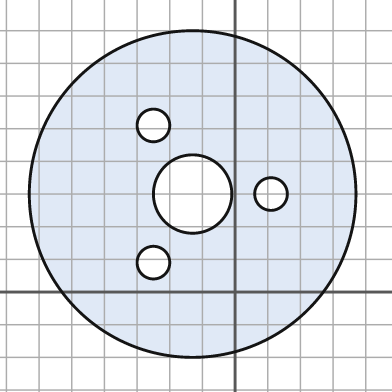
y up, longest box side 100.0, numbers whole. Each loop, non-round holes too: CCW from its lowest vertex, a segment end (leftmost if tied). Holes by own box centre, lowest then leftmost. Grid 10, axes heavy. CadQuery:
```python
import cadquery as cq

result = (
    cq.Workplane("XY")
    .moveTo(-13.0, 30.0)
    .circle(50.0)
    .moveTo(-25.0, 9.0)
    .circle(5.0)
    .moveTo(-13.0, 30.0)
    .circle(12.0)
    .moveTo(11.0, 30.0)
    .circle(5.0)
    .moveTo(-25.0, 51.0)
    .circle(5.0)
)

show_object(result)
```